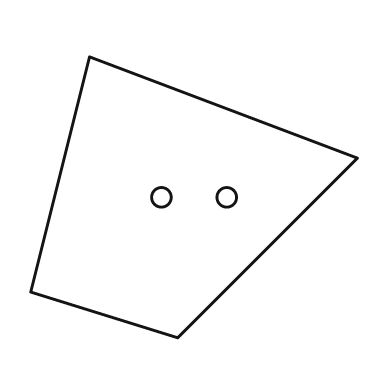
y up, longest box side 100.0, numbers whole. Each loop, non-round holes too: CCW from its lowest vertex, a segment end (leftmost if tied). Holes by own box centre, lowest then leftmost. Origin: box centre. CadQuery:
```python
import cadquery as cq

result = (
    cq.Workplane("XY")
    .moveTo(-5.0, -43.0)
    .lineTo(50.0, 12.0)
    .lineTo(-32.0, 43.0)
    .lineTo(-50.0, -29.0)
    .close()
    .moveTo(-10.0, 0.0)
    .circle(3.0)
    .moveTo(10.0, 0.0)
    .circle(3.0)
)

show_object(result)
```